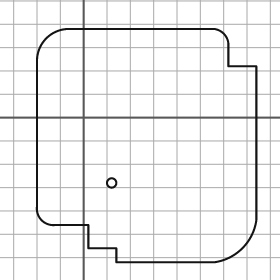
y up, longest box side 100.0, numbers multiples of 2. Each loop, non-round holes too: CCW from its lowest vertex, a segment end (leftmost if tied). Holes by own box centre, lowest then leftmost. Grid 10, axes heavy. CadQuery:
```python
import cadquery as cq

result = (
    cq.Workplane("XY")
    .moveTo(14.0, -62.0)
    .lineTo(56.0, -62.0)
    .threePointArc((68.0, -56.0), (74.0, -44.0))
    .lineTo(74.0, 22.0)
    .lineTo(62.0, 22.0)
    .lineTo(62.0, 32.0)
    .threePointArc((60.0, 36.0), (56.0, 38.0))
    .lineTo(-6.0, 38.0)
    .threePointArc((-16.0, 34.0), (-20.0, 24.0))
    .lineTo(-20.0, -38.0)
    .threePointArc((-18.0, -44.0), (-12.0, -46.0))
    .lineTo(2.0, -46.0)
    .lineTo(2.0, -56.0)
    .lineTo(14.0, -56.0)
    .close()
    .moveTo(12.0, -28.0)
    .circle(2.0)
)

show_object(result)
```